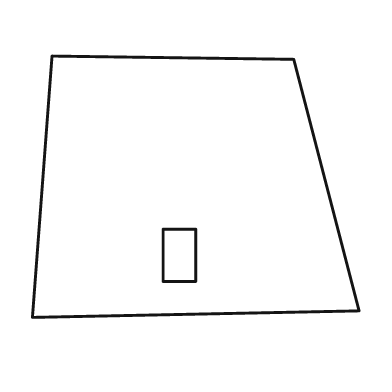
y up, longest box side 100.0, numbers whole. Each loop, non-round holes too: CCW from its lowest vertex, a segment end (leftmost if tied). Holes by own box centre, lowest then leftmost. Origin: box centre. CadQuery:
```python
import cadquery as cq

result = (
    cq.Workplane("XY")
    .moveTo(-50.0, -40.0)
    .lineTo(50.0, -38.0)
    .lineTo(30.0, 39.0)
    .lineTo(-44.0, 40.0)
    .close()
    .moveTo(-10.0, -29.0)
    .lineTo(0.0, -29.0)
    .lineTo(0.0, -13.0)
    .lineTo(-10.0, -13.0)
    .close()
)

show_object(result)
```